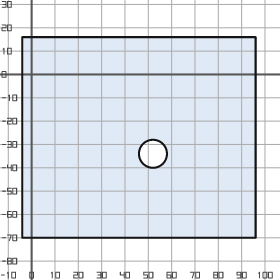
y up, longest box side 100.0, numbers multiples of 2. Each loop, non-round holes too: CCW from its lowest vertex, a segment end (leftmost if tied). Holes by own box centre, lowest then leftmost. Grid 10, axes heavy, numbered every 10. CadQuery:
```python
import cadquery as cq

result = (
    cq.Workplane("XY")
    .moveTo(-4.0, -70.0)
    .lineTo(96.0, -70.0)
    .lineTo(96.0, 16.0)
    .lineTo(-4.0, 16.0)
    .close()
    .moveTo(52.0, -34.0)
    .circle(6.0)
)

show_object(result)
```